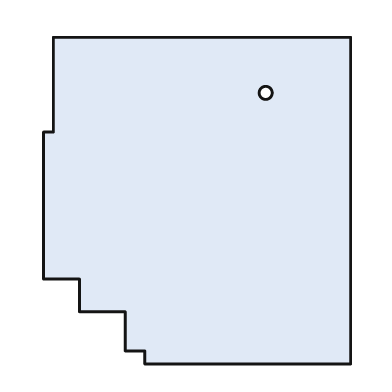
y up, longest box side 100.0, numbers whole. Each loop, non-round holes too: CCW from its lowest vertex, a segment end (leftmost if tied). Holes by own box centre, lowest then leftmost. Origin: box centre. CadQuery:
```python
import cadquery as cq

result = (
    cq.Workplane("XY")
    .moveTo(-16.0, -50.0)
    .lineTo(47.0, -50.0)
    .lineTo(47.0, 50.0)
    .lineTo(-44.0, 50.0)
    .lineTo(-44.0, 21.0)
    .lineTo(-47.0, 21.0)
    .lineTo(-47.0, -24.0)
    .lineTo(-36.0, -24.0)
    .lineTo(-36.0, -34.0)
    .lineTo(-22.0, -34.0)
    .lineTo(-22.0, -46.0)
    .lineTo(-16.0, -46.0)
    .close()
    .moveTo(21.0, 33.0)
    .circle(2.0)
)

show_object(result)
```